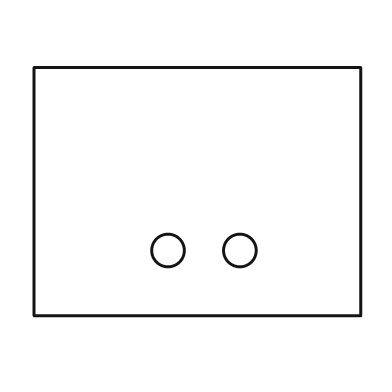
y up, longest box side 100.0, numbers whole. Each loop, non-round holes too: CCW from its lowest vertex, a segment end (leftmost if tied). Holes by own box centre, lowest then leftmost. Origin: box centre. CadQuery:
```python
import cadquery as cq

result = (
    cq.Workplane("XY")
    .moveTo(-50.0, -38.0)
    .lineTo(50.0, -38.0)
    .lineTo(50.0, 38.0)
    .lineTo(-50.0, 38.0)
    .close()
    .moveTo(-9.0, -18.0)
    .circle(5.0)
    .moveTo(13.0, -18.0)
    .circle(5.0)
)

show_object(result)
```